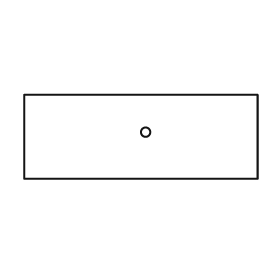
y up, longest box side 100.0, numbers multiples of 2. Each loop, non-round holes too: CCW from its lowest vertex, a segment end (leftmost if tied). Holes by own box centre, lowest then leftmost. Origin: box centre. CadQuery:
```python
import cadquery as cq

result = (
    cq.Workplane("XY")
    .moveTo(-50.0, -18.0)
    .lineTo(50.0, -18.0)
    .lineTo(50.0, 18.0)
    .lineTo(-50.0, 18.0)
    .close()
    .moveTo(2.0, 2.0)
    .circle(2.0)
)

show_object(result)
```